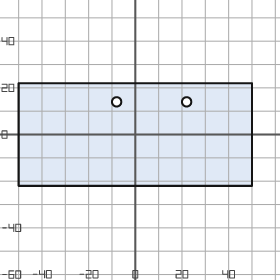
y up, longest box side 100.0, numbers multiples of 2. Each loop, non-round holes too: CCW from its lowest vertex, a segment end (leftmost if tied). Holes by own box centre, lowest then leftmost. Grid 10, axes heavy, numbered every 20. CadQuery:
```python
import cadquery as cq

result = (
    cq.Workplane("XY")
    .moveTo(-50.0, -22.0)
    .lineTo(50.0, -22.0)
    .lineTo(50.0, 22.0)
    .lineTo(-50.0, 22.0)
    .close()
    .moveTo(-8.0, 14.0)
    .circle(2.0)
    .moveTo(22.0, 14.0)
    .circle(2.0)
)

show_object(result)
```